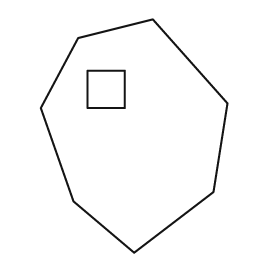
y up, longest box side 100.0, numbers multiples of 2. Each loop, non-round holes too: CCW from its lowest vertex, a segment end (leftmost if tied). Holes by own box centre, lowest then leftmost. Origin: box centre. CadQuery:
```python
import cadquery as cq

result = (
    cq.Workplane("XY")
    .moveTo(0.0, -50.0)
    .lineTo(34.0, -24.0)
    .lineTo(40.0, 14.0)
    .lineTo(8.0, 50.0)
    .lineTo(-24.0, 42.0)
    .lineTo(-40.0, 12.0)
    .lineTo(-26.0, -28.0)
    .close()
    .moveTo(-20.0, 12.0)
    .lineTo(-4.0, 12.0)
    .lineTo(-4.0, 28.0)
    .lineTo(-20.0, 28.0)
    .close()
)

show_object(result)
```